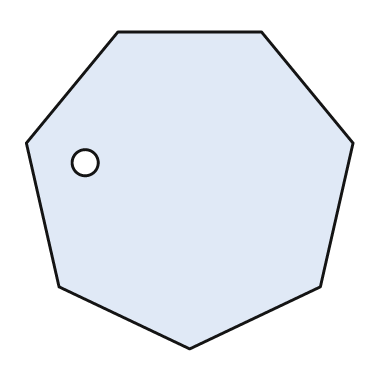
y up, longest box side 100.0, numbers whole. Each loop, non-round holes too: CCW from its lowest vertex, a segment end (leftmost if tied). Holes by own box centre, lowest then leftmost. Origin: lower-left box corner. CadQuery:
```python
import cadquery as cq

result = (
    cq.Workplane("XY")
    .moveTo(50.0, 0.0)
    .lineTo(90.0, 19.0)
    .lineTo(100.0, 63.0)
    .lineTo(72.0, 97.0)
    .lineTo(28.0, 97.0)
    .lineTo(0.0, 63.0)
    .lineTo(10.0, 19.0)
    .close()
    .moveTo(18.0, 57.0)
    .circle(4.0)
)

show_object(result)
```